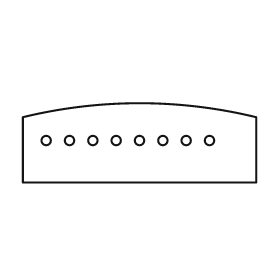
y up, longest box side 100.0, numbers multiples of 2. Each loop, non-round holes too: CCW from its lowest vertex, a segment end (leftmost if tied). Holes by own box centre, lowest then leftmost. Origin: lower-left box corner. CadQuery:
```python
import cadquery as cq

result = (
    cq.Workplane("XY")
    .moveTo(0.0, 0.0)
    .lineTo(100.0, 0.0)
    .lineTo(100.0, 28.0)
    .threePointArc((50.0, 34.0), (0.0, 28.0))
    .close()
    .moveTo(10.0, 18.0)
    .circle(2.0)
    .moveTo(20.0, 18.0)
    .circle(2.0)
    .moveTo(30.0, 18.0)
    .circle(2.0)
    .moveTo(40.0, 18.0)
    .circle(2.0)
    .moveTo(50.0, 18.0)
    .circle(2.0)
    .moveTo(60.0, 18.0)
    .circle(2.0)
    .moveTo(70.0, 18.0)
    .circle(2.0)
    .moveTo(80.0, 18.0)
    .circle(2.0)
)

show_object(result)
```